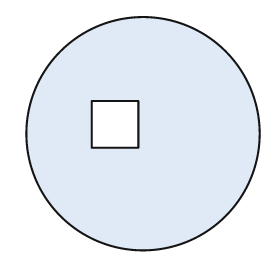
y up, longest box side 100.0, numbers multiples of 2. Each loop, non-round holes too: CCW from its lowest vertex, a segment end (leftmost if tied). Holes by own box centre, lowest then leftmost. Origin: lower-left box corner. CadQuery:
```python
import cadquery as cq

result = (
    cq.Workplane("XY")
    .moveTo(50.0, 50.0)
    .circle(50.0)
    .moveTo(28.0, 44.0)
    .lineTo(48.0, 44.0)
    .lineTo(48.0, 64.0)
    .lineTo(28.0, 64.0)
    .close()
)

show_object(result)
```